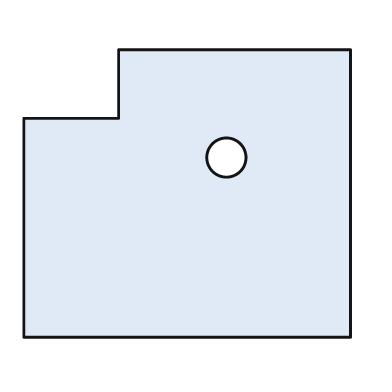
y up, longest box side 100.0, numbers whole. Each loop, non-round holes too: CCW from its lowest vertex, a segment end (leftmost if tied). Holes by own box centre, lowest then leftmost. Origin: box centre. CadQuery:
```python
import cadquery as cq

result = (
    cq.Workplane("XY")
    .moveTo(-50.0, -44.0)
    .lineTo(50.0, -44.0)
    .lineTo(50.0, 44.0)
    .lineTo(-21.0, 44.0)
    .lineTo(-21.0, 23.0)
    .lineTo(-50.0, 23.0)
    .close()
    .moveTo(12.0, 11.0)
    .circle(6.0)
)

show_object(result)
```